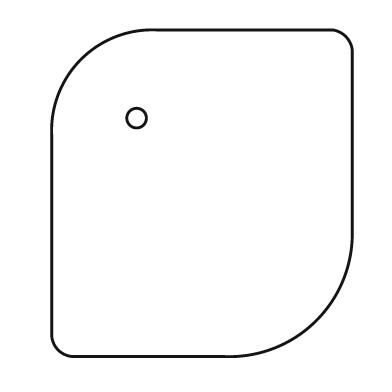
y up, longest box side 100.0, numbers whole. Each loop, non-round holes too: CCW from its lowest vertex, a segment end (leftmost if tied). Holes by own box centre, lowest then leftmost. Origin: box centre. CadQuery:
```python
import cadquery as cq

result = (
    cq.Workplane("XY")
    .moveTo(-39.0, -50.0)
    .lineTo(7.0, -50.0)
    .threePointArc((35.0, -39.0), (46.0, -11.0))
    .lineTo(46.0, 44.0)
    .threePointArc((44.0, 48.0), (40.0, 50.0))
    .lineTo(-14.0, 50.0)
    .threePointArc((-37.0, 41.0), (-46.0, 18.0))
    .lineTo(-46.0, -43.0)
    .threePointArc((-44.0, -48.0), (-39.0, -50.0))
    .close()
    .moveTo(-20.0, 23.0)
    .circle(3.0)
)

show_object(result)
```